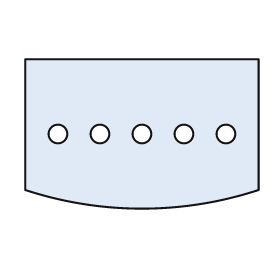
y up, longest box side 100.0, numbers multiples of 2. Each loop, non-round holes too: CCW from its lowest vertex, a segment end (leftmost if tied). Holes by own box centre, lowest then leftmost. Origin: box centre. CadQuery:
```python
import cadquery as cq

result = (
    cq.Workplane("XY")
    .moveTo(-50.0, -24.0)
    .threePointArc((0.0, -32.0), (50.0, -24.0))
    .lineTo(50.0, 32.0)
    .lineTo(-50.0, 32.0)
    .close()
    .moveTo(-36.0, 0.0)
    .circle(4.0)
    .moveTo(-18.0, 0.0)
    .circle(4.0)
    .moveTo(0.0, 0.0)
    .circle(4.0)
    .moveTo(18.0, 0.0)
    .circle(4.0)
    .moveTo(36.0, 0.0)
    .circle(4.0)
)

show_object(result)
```